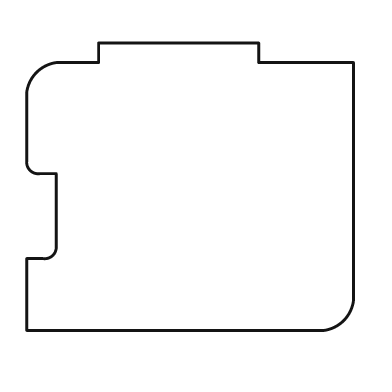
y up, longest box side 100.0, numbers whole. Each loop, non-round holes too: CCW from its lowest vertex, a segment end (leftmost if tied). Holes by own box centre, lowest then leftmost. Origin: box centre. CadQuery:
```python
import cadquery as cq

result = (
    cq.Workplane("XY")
    .moveTo(-50.0, -44.0)
    .lineTo(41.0, -44.0)
    .threePointArc((47.0, -41.0), (50.0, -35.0))
    .lineTo(50.0, 38.0)
    .lineTo(21.0, 38.0)
    .lineTo(21.0, 44.0)
    .lineTo(-28.0, 44.0)
    .lineTo(-28.0, 38.0)
    .lineTo(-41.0, 38.0)
    .threePointArc((-47.0, 35.0), (-50.0, 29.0))
    .lineTo(-50.0, 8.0)
    .threePointArc((-49.0, 5.0), (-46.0, 4.0))
    .lineTo(-41.0, 4.0)
    .lineTo(-41.0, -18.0)
    .threePointArc((-42.0, -21.0), (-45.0, -22.0))
    .lineTo(-50.0, -22.0)
    .close()
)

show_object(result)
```